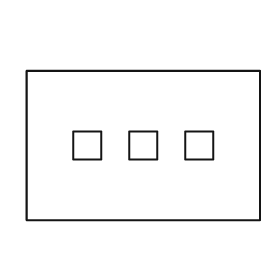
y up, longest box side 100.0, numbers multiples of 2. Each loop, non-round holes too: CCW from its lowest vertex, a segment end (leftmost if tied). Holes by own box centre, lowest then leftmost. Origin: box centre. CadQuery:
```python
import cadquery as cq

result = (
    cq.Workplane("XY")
    .moveTo(-50.0, -32.0)
    .lineTo(50.0, -32.0)
    .lineTo(50.0, 32.0)
    .lineTo(-50.0, 32.0)
    .close()
    .moveTo(-30.0, -6.0)
    .lineTo(-18.0, -6.0)
    .lineTo(-18.0, 6.0)
    .lineTo(-30.0, 6.0)
    .close()
    .moveTo(-6.0, -6.0)
    .lineTo(6.0, -6.0)
    .lineTo(6.0, 6.0)
    .lineTo(-6.0, 6.0)
    .close()
    .moveTo(18.0, -6.0)
    .lineTo(30.0, -6.0)
    .lineTo(30.0, 6.0)
    .lineTo(18.0, 6.0)
    .close()
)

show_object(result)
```